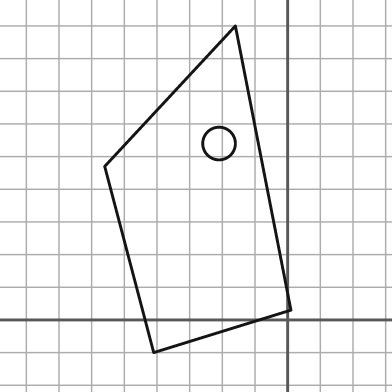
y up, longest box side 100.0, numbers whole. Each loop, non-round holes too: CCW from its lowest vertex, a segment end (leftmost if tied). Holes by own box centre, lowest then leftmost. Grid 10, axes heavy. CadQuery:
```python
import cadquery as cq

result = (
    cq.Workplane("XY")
    .moveTo(-41.0, -10.0)
    .lineTo(1.0, 3.0)
    .lineTo(-16.0, 90.0)
    .lineTo(-56.0, 47.0)
    .close()
    .moveTo(-21.0, 54.0)
    .circle(5.0)
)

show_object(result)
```